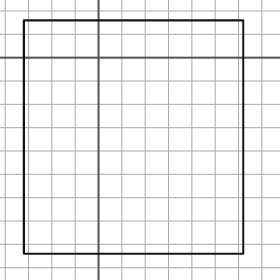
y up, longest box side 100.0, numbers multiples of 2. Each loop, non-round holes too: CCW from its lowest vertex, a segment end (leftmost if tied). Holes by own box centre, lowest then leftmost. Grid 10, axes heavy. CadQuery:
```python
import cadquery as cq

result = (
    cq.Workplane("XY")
    .moveTo(-32.0, -84.0)
    .lineTo(62.0, -84.0)
    .lineTo(62.0, 16.0)
    .lineTo(-32.0, 16.0)
    .close()
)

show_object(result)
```